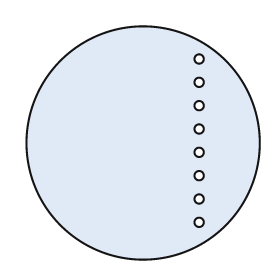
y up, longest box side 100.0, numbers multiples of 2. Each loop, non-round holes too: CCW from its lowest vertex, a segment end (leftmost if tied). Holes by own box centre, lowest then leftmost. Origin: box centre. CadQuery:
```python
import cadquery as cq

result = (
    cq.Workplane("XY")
    .moveTo(0.0, 0.0)
    .circle(50.0)
    .moveTo(24.0, -34.0)
    .circle(2.0)
    .moveTo(24.0, -24.0)
    .circle(2.0)
    .moveTo(24.0, -14.0)
    .circle(2.0)
    .moveTo(24.0, -4.0)
    .circle(2.0)
    .moveTo(24.0, 6.0)
    .circle(2.0)
    .moveTo(24.0, 16.0)
    .circle(2.0)
    .moveTo(24.0, 26.0)
    .circle(2.0)
    .moveTo(24.0, 36.0)
    .circle(2.0)
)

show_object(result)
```